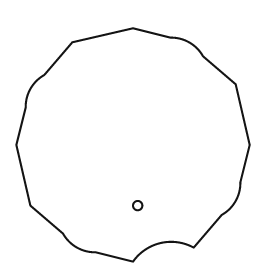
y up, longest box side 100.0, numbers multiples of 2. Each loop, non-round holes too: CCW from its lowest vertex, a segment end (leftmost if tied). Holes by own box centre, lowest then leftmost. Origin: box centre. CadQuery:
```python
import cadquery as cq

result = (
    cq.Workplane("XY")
    .moveTo(0.0, -50.0)
    .threePointArc((12.0, -42.0), (26.0, -44.0))
    .lineTo(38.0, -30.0)
    .threePointArc((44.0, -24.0), (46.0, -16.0))
    .lineTo(50.0, 0.0)
    .lineTo(44.0, 26.0)
    .lineTo(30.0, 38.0)
    .threePointArc((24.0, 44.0), (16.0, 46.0))
    .lineTo(0.0, 50.0)
    .lineTo(-26.0, 44.0)
    .lineTo(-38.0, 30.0)
    .threePointArc((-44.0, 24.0), (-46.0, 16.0))
    .lineTo(-50.0, 0.0)
    .lineTo(-44.0, -26.0)
    .lineTo(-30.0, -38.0)
    .threePointArc((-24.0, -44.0), (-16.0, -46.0))
    .close()
    .moveTo(2.0, -26.0)
    .circle(2.0)
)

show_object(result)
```